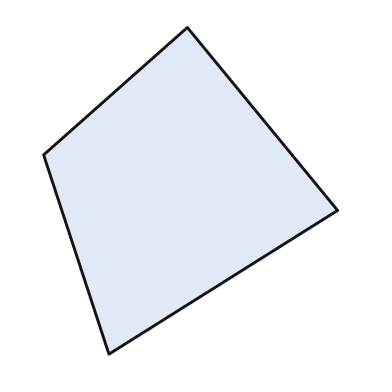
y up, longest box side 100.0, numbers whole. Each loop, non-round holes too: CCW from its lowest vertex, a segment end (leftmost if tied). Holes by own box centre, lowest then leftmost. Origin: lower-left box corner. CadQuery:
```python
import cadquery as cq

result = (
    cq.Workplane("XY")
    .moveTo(20.0, 0.0)
    .lineTo(90.0, 44.0)
    .lineTo(44.0, 100.0)
    .lineTo(0.0, 61.0)
    .close()
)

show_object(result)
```